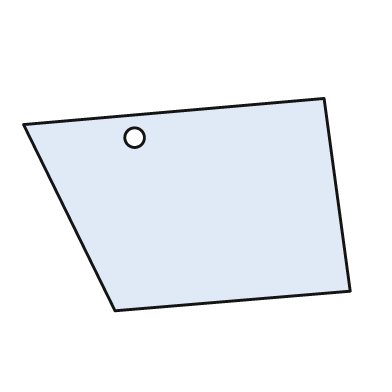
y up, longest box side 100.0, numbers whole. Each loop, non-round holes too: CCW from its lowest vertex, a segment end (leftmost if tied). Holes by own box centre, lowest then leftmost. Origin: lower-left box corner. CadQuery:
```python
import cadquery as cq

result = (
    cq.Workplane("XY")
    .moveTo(28.0, 0.0)
    .lineTo(100.0, 6.0)
    .lineTo(92.0, 65.0)
    .lineTo(0.0, 57.0)
    .close()
    .moveTo(34.0, 53.0)
    .circle(3.0)
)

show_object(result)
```